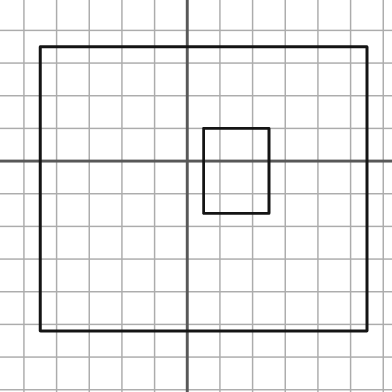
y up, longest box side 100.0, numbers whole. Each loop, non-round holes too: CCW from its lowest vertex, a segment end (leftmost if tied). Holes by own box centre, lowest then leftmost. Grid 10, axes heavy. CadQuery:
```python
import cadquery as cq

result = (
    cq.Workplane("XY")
    .moveTo(-45.0, -52.0)
    .lineTo(55.0, -52.0)
    .lineTo(55.0, 35.0)
    .lineTo(-45.0, 35.0)
    .close()
    .moveTo(5.0, -16.0)
    .lineTo(25.0, -16.0)
    .lineTo(25.0, 10.0)
    .lineTo(5.0, 10.0)
    .close()
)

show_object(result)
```